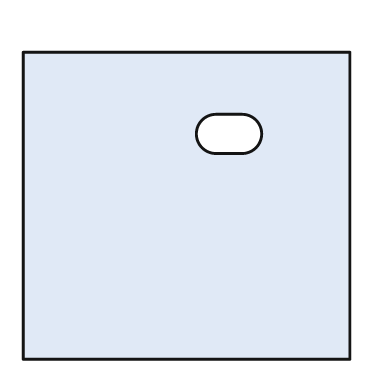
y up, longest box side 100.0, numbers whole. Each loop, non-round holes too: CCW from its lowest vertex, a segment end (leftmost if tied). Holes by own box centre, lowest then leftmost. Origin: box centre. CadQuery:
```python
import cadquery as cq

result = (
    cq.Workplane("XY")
    .moveTo(-50.0, -47.0)
    .lineTo(50.0, -47.0)
    .lineTo(50.0, 47.0)
    .lineTo(-50.0, 47.0)
    .close()
    .moveTo(9.0, 16.0)
    .lineTo(17.0, 16.0)
    .threePointArc((23.0, 22.0), (17.0, 28.0))
    .lineTo(9.0, 28.0)
    .threePointArc((3.0, 22.0), (9.0, 16.0))
    .close()
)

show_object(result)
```